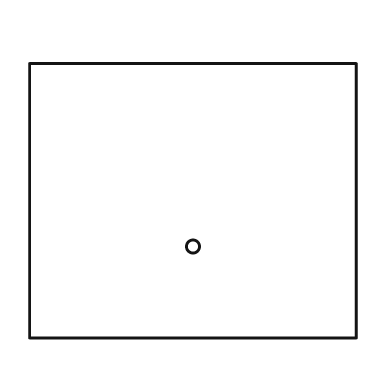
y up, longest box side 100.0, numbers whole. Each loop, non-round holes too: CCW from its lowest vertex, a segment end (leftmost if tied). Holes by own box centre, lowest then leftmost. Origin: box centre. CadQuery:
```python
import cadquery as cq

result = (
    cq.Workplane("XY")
    .moveTo(-50.0, -42.0)
    .lineTo(50.0, -42.0)
    .lineTo(50.0, 42.0)
    .lineTo(-50.0, 42.0)
    .close()
    .moveTo(0.0, -14.0)
    .circle(2.0)
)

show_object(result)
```